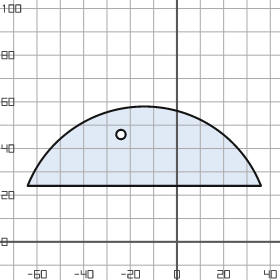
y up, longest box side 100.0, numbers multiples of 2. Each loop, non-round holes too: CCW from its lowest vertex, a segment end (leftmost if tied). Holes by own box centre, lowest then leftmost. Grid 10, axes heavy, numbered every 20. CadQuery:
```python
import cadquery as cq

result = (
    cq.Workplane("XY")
    .moveTo(-64.0, 24.0)
    .lineTo(36.0, 24.0)
    .threePointArc((-14.0, 58.0), (-64.0, 24.0))
    .close()
    .moveTo(-24.0, 46.0)
    .circle(2.0)
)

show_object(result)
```